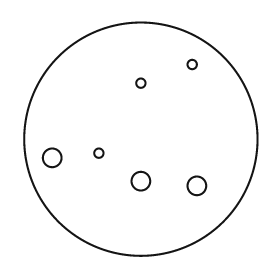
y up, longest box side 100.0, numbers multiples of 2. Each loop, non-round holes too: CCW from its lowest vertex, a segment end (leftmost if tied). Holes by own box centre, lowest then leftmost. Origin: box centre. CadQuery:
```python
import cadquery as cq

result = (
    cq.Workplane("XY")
    .moveTo(0.0, 0.0)
    .circle(50.0)
    .moveTo(24.0, -20.0)
    .circle(4.0)
    .moveTo(0.0, -18.0)
    .circle(4.0)
    .moveTo(-38.0, -8.0)
    .circle(4.0)
    .moveTo(-18.0, -6.0)
    .circle(2.0)
    .moveTo(0.0, 24.0)
    .circle(2.0)
    .moveTo(22.0, 32.0)
    .circle(2.0)
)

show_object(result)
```